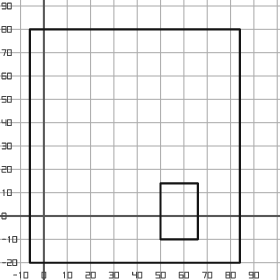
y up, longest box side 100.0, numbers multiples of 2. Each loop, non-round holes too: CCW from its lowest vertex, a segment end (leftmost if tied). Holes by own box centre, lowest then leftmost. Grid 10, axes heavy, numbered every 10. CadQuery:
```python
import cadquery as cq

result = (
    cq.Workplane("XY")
    .moveTo(-6.0, -20.0)
    .lineTo(84.0, -20.0)
    .lineTo(84.0, 80.0)
    .lineTo(-6.0, 80.0)
    .close()
    .moveTo(50.0, -10.0)
    .lineTo(66.0, -10.0)
    .lineTo(66.0, 14.0)
    .lineTo(50.0, 14.0)
    .close()
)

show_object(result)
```